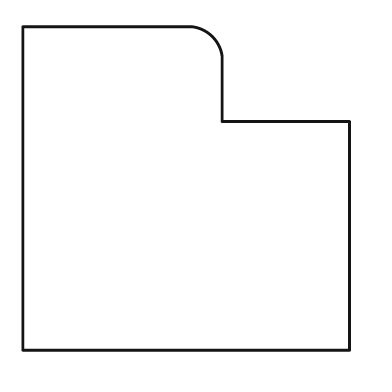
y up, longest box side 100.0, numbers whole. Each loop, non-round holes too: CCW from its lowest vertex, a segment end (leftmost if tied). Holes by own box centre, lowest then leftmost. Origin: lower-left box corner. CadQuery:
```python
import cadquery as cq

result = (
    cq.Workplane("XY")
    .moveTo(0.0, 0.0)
    .lineTo(100.0, 0.0)
    .lineTo(100.0, 70.0)
    .lineTo(61.0, 70.0)
    .lineTo(61.0, 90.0)
    .threePointArc((58.0, 96.0), (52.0, 99.0))
    .lineTo(0.0, 99.0)
    .close()
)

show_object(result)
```